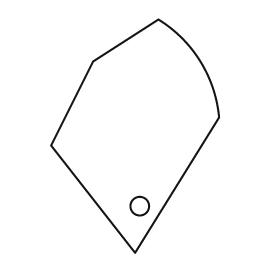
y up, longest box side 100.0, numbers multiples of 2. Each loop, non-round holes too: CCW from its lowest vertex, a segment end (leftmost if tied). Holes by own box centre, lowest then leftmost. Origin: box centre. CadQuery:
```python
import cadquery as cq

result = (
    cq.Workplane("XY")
    .moveTo(0.0, -50.0)
    .lineTo(36.0, 8.0)
    .threePointArc((28.0, 32.0), (10.0, 50.0))
    .lineTo(-18.0, 32.0)
    .lineTo(-36.0, -4.0)
    .close()
    .moveTo(2.0, -30.0)
    .circle(4.0)
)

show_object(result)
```